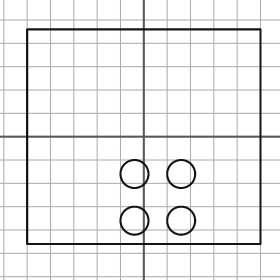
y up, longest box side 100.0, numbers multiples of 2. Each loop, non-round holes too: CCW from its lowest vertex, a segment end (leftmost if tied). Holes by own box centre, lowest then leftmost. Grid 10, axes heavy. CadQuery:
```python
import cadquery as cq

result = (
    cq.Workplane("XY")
    .moveTo(-50.0, -46.0)
    .lineTo(50.0, -46.0)
    .lineTo(50.0, 46.0)
    .lineTo(-50.0, 46.0)
    .close()
    .moveTo(-4.0, -36.0)
    .circle(6.0)
    .moveTo(16.0, -36.0)
    .circle(6.0)
    .moveTo(-4.0, -16.0)
    .circle(6.0)
    .moveTo(16.0, -16.0)
    .circle(6.0)
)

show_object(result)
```